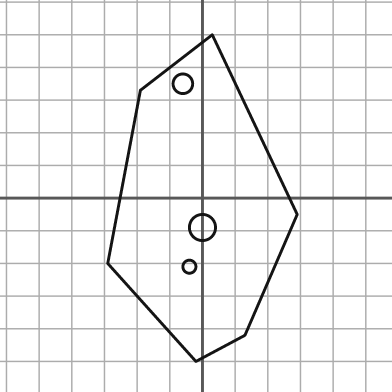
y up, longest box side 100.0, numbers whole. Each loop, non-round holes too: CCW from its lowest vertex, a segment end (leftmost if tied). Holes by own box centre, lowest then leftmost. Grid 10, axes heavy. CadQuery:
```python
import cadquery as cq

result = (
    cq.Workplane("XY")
    .moveTo(-2.0, -50.0)
    .lineTo(13.0, -42.0)
    .lineTo(29.0, -5.0)
    .lineTo(3.0, 50.0)
    .lineTo(-19.0, 33.0)
    .lineTo(-29.0, -20.0)
    .close()
    .moveTo(-4.0, -21.0)
    .circle(2.0)
    .moveTo(0.0, -9.0)
    .circle(4.0)
    .moveTo(-6.0, 35.0)
    .circle(3.0)
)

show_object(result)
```